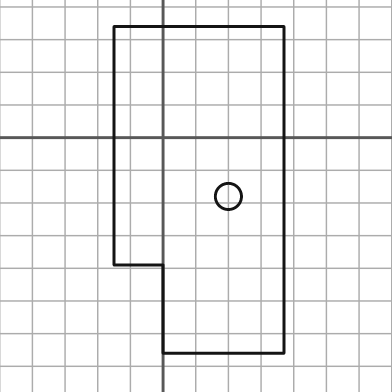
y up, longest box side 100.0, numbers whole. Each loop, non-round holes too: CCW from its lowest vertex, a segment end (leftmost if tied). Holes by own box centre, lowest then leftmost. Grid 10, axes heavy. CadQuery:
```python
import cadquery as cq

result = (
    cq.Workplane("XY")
    .moveTo(0.0, -66.0)
    .lineTo(37.0, -66.0)
    .lineTo(37.0, 34.0)
    .lineTo(-15.0, 34.0)
    .lineTo(-15.0, -39.0)
    .lineTo(0.0, -39.0)
    .close()
    .moveTo(20.0, -18.0)
    .circle(4.0)
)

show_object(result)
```